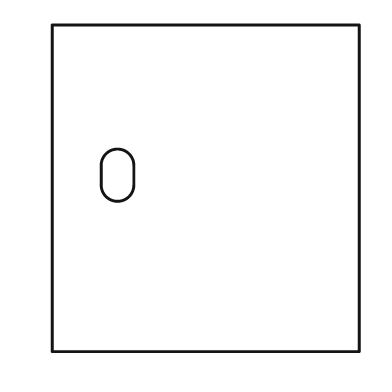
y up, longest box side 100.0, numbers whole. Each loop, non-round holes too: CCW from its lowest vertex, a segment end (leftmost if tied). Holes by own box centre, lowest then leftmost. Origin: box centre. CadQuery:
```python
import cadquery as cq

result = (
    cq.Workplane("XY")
    .moveTo(-47.0, -50.0)
    .lineTo(47.0, -50.0)
    .lineTo(47.0, 50.0)
    .lineTo(-47.0, 50.0)
    .close()
    .moveTo(-32.0, 1.0)
    .threePointArc((-27.0, -4.0), (-22.0, 1.0))
    .lineTo(-22.0, 7.0)
    .threePointArc((-27.0, 12.0), (-32.0, 7.0))
    .close()
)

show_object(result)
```